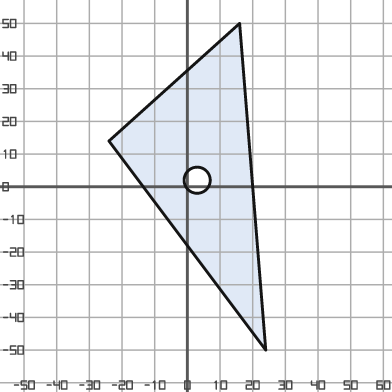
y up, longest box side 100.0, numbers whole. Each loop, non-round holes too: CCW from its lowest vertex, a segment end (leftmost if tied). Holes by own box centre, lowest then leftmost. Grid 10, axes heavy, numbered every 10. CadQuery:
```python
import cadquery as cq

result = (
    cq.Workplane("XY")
    .moveTo(24.0, -50.0)
    .lineTo(16.0, 50.0)
    .lineTo(-24.0, 14.0)
    .close()
    .moveTo(3.0, 2.0)
    .circle(4.0)
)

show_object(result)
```